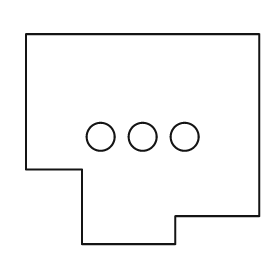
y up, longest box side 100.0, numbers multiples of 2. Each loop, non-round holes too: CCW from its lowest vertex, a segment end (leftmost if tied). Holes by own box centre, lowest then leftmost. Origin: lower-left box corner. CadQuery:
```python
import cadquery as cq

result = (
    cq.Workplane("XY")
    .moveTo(24.0, 0.0)
    .lineTo(64.0, 0.0)
    .lineTo(64.0, 12.0)
    .lineTo(100.0, 12.0)
    .lineTo(100.0, 90.0)
    .lineTo(0.0, 90.0)
    .lineTo(0.0, 32.0)
    .lineTo(24.0, 32.0)
    .close()
    .moveTo(32.0, 46.0)
    .circle(6.0)
    .moveTo(50.0, 46.0)
    .circle(6.0)
    .moveTo(68.0, 46.0)
    .circle(6.0)
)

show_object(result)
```